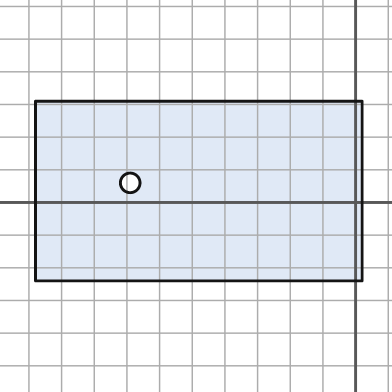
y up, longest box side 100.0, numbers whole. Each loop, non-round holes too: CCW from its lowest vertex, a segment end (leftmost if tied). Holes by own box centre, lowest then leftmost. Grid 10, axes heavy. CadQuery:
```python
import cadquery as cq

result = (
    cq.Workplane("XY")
    .moveTo(-98.0, -24.0)
    .lineTo(2.0, -24.0)
    .lineTo(2.0, 31.0)
    .lineTo(-98.0, 31.0)
    .close()
    .moveTo(-69.0, 6.0)
    .circle(3.0)
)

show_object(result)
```